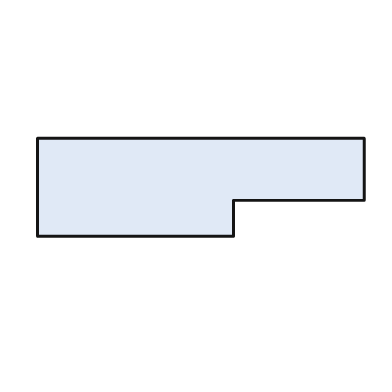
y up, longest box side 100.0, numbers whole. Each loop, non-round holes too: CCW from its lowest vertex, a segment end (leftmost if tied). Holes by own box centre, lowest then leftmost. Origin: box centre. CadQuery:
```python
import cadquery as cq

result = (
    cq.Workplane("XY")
    .moveTo(-50.0, -15.0)
    .lineTo(10.0, -15.0)
    .lineTo(10.0, -4.0)
    .lineTo(50.0, -4.0)
    .lineTo(50.0, 15.0)
    .lineTo(-50.0, 15.0)
    .close()
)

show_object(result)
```